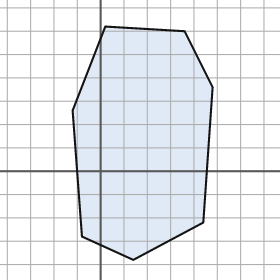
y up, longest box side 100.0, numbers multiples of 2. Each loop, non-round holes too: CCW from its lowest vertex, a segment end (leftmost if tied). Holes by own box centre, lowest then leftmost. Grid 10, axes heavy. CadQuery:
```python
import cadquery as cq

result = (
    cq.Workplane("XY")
    .moveTo(14.0, -38.0)
    .lineTo(44.0, -22.0)
    .lineTo(48.0, 36.0)
    .lineTo(36.0, 60.0)
    .lineTo(2.0, 62.0)
    .lineTo(-12.0, 26.0)
    .lineTo(-8.0, -28.0)
    .close()
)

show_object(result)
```